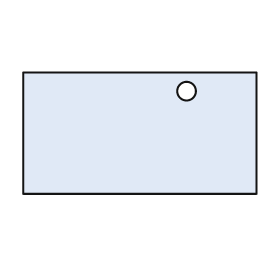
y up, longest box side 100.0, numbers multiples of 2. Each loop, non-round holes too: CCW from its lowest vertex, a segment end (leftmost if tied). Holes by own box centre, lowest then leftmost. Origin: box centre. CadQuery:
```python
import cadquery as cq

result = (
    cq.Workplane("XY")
    .moveTo(-50.0, -26.0)
    .lineTo(50.0, -26.0)
    .lineTo(50.0, 26.0)
    .lineTo(-50.0, 26.0)
    .close()
    .moveTo(20.0, 18.0)
    .circle(4.0)
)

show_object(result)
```